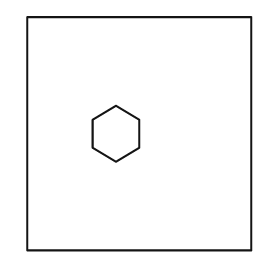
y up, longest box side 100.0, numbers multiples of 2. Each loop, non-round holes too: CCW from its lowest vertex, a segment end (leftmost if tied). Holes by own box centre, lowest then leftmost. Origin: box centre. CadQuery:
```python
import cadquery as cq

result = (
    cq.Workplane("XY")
    .moveTo(-48.0, -50.0)
    .lineTo(48.0, -50.0)
    .lineTo(48.0, 50.0)
    .lineTo(-48.0, 50.0)
    .close()
    .moveTo(-10.0, -12.0)
    .lineTo(0.0, -6.0)
    .lineTo(0.0, 6.0)
    .lineTo(-10.0, 12.0)
    .lineTo(-20.0, 6.0)
    .lineTo(-20.0, -6.0)
    .close()
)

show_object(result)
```